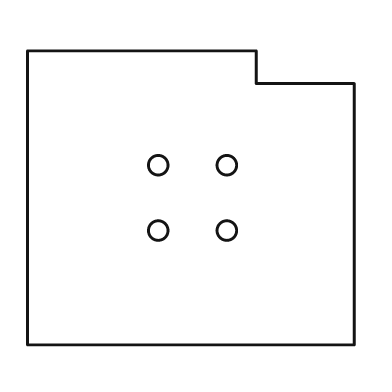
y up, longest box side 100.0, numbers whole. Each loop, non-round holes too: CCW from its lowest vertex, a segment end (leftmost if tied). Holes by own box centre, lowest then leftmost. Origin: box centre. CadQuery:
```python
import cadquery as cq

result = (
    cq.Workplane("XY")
    .moveTo(-50.0, -45.0)
    .lineTo(50.0, -45.0)
    .lineTo(50.0, 35.0)
    .lineTo(20.0, 35.0)
    .lineTo(20.0, 45.0)
    .lineTo(-50.0, 45.0)
    .close()
    .moveTo(-10.0, -10.0)
    .circle(3.0)
    .moveTo(11.0, -10.0)
    .circle(3.0)
    .moveTo(-10.0, 10.0)
    .circle(3.0)
    .moveTo(11.0, 10.0)
    .circle(3.0)
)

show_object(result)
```